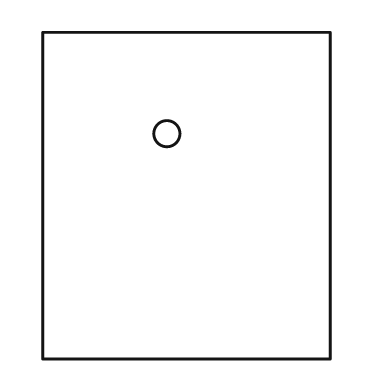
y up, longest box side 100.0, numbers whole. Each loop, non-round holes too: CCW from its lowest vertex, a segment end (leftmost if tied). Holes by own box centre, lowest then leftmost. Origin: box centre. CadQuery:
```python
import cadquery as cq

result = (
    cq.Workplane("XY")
    .moveTo(-44.0, -50.0)
    .lineTo(44.0, -50.0)
    .lineTo(44.0, 50.0)
    .lineTo(-44.0, 50.0)
    .close()
    .moveTo(-6.0, 19.0)
    .circle(4.0)
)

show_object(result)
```